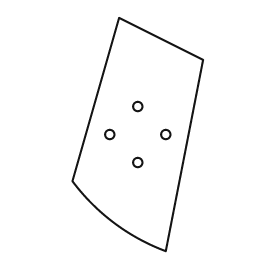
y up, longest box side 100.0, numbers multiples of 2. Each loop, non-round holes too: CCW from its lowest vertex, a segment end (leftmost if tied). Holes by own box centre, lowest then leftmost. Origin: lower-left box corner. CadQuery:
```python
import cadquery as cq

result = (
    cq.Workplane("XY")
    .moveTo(40.0, 0.0)
    .lineTo(56.0, 82.0)
    .lineTo(20.0, 100.0)
    .lineTo(0.0, 30.0)
    .threePointArc((18.0, 12.0), (40.0, 0.0))
    .close()
    .moveTo(28.0, 38.0)
    .circle(2.0)
    .moveTo(16.0, 50.0)
    .circle(2.0)
    .moveTo(40.0, 50.0)
    .circle(2.0)
    .moveTo(28.0, 62.0)
    .circle(2.0)
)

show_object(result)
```